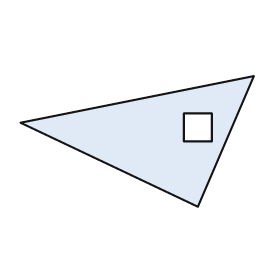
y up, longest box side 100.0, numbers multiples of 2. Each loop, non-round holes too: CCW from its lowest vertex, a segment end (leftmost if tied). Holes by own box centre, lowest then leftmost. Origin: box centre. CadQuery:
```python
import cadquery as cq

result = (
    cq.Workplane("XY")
    .moveTo(26.0, -28.0)
    .lineTo(50.0, 28.0)
    .lineTo(-50.0, 8.0)
    .close()
    .moveTo(20.0, 0.0)
    .lineTo(32.0, 0.0)
    .lineTo(32.0, 12.0)
    .lineTo(20.0, 12.0)
    .close()
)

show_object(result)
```